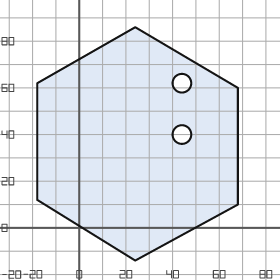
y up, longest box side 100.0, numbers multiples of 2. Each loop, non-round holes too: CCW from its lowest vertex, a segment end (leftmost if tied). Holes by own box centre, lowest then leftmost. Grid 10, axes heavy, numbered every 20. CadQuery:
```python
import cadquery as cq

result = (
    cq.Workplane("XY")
    .moveTo(24.0, -14.0)
    .lineTo(68.0, 10.0)
    .lineTo(68.0, 60.0)
    .lineTo(24.0, 86.0)
    .lineTo(-18.0, 62.0)
    .lineTo(-18.0, 12.0)
    .close()
    .moveTo(44.0, 40.0)
    .circle(4.0)
    .moveTo(44.0, 62.0)
    .circle(4.0)
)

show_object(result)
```